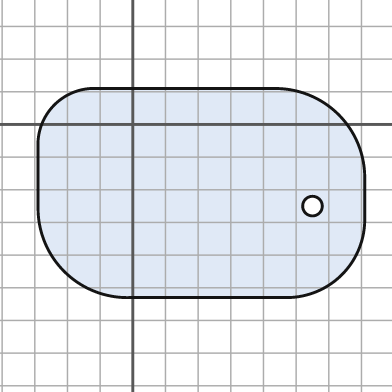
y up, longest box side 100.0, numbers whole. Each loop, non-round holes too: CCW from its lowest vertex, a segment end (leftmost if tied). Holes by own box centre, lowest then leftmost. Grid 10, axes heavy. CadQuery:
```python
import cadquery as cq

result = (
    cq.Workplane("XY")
    .moveTo(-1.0, -53.0)
    .lineTo(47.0, -53.0)
    .threePointArc((64.0, -46.0), (71.0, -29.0))
    .lineTo(71.0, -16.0)
    .threePointArc((63.0, 3.0), (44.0, 11.0))
    .lineTo(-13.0, 11.0)
    .threePointArc((-24.0, 6.0), (-29.0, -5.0))
    .lineTo(-29.0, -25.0)
    .threePointArc((-21.0, -45.0), (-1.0, -53.0))
    .close()
    .moveTo(55.0, -25.0)
    .circle(3.0)
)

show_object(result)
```